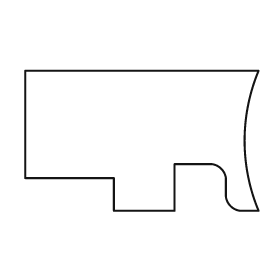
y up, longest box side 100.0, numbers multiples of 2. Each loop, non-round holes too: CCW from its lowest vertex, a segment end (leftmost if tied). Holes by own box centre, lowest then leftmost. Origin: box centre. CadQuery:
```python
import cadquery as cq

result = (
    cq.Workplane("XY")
    .moveTo(-12.0, -30.0)
    .lineTo(14.0, -30.0)
    .lineTo(14.0, -10.0)
    .lineTo(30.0, -10.0)
    .threePointArc((34.0, -12.0), (36.0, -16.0))
    .lineTo(36.0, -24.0)
    .threePointArc((38.0, -28.0), (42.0, -30.0))
    .lineTo(50.0, -30.0)
    .threePointArc((44.0, 0.0), (50.0, 30.0))
    .lineTo(-50.0, 30.0)
    .lineTo(-50.0, -16.0)
    .lineTo(-12.0, -16.0)
    .close()
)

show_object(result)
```